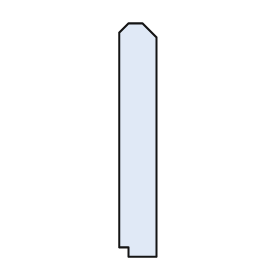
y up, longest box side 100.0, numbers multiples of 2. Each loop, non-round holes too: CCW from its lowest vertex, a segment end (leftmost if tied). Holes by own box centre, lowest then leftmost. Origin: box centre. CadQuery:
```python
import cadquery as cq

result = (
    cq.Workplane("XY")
    .moveTo(-4.0, -50.0)
    .lineTo(8.0, -50.0)
    .lineTo(8.0, 44.0)
    .lineTo(2.0, 50.0)
    .lineTo(-4.0, 50.0)
    .lineTo(-8.0, 46.0)
    .lineTo(-8.0, -46.0)
    .lineTo(-4.0, -46.0)
    .close()
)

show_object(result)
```